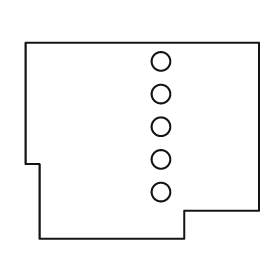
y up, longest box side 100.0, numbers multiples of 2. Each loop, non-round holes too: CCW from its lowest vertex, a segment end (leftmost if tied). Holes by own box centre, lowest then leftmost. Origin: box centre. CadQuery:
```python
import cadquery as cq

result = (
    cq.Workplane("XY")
    .moveTo(-44.0, -42.0)
    .lineTo(18.0, -42.0)
    .lineTo(18.0, -30.0)
    .lineTo(50.0, -30.0)
    .lineTo(50.0, 42.0)
    .lineTo(-50.0, 42.0)
    .lineTo(-50.0, -10.0)
    .lineTo(-44.0, -10.0)
    .close()
    .moveTo(8.0, -22.0)
    .circle(4.0)
    .moveTo(8.0, -8.0)
    .circle(4.0)
    .moveTo(8.0, 6.0)
    .circle(4.0)
    .moveTo(8.0, 20.0)
    .circle(4.0)
    .moveTo(8.0, 34.0)
    .circle(4.0)
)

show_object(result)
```